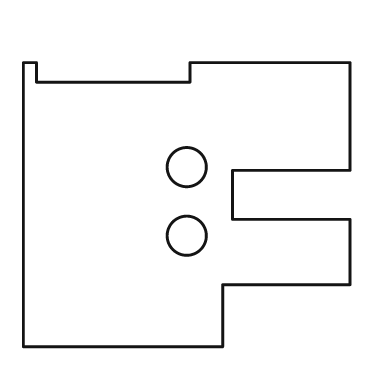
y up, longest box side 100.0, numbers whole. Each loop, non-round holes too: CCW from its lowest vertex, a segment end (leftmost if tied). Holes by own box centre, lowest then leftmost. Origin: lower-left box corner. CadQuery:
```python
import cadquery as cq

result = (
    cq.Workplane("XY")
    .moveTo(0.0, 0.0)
    .lineTo(61.0, 0.0)
    .lineTo(61.0, 19.0)
    .lineTo(100.0, 19.0)
    .lineTo(100.0, 39.0)
    .lineTo(64.0, 39.0)
    .lineTo(64.0, 54.0)
    .lineTo(100.0, 54.0)
    .lineTo(100.0, 87.0)
    .lineTo(51.0, 87.0)
    .lineTo(51.0, 81.0)
    .lineTo(4.0, 81.0)
    .lineTo(4.0, 87.0)
    .lineTo(0.0, 87.0)
    .close()
    .moveTo(50.0, 34.0)
    .circle(6.0)
    .moveTo(50.0, 55.0)
    .circle(6.0)
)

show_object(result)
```